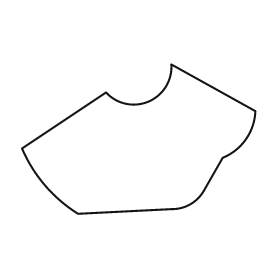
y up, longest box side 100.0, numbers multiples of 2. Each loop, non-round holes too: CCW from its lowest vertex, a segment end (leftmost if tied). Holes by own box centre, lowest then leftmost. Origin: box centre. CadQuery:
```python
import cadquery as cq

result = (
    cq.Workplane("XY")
    .moveTo(-26.0, -32.0)
    .lineTo(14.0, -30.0)
    .threePointArc((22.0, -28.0), (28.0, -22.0))
    .lineTo(36.0, -8.0)
    .threePointArc((46.0, 0.0), (50.0, 12.0))
    .lineTo(14.0, 32.0)
    .threePointArc((4.0, 16.0), (-14.0, 20.0))
    .lineTo(-50.0, -4.0)
    .threePointArc((-40.0, -20.0), (-26.0, -32.0))
    .close()
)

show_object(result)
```